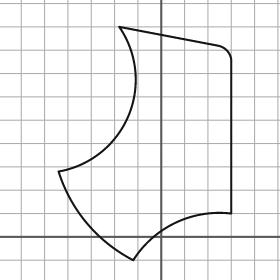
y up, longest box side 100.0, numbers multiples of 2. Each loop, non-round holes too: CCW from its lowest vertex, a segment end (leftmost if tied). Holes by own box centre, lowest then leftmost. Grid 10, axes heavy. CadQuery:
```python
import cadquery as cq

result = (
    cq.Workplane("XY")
    .moveTo(-12.0, -10.0)
    .threePointArc((6.0, 6.0), (30.0, 10.0))
    .lineTo(30.0, 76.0)
    .threePointArc((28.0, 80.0), (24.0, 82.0))
    .lineTo(-18.0, 90.0)
    .threePointArc((-14.0, 52.0), (-44.0, 28.0))
    .threePointArc((-32.0, 6.0), (-12.0, -10.0))
    .close()
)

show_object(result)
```